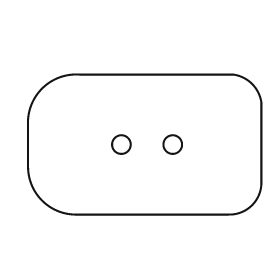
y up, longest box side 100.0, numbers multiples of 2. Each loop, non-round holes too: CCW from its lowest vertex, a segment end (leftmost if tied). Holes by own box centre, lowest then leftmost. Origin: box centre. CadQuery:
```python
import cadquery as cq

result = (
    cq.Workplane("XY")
    .moveTo(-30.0, -30.0)
    .lineTo(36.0, -30.0)
    .threePointArc((46.0, -26.0), (50.0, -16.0))
    .lineTo(50.0, 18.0)
    .threePointArc((46.0, 26.0), (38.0, 30.0))
    .lineTo(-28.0, 30.0)
    .threePointArc((-44.0, 24.0), (-50.0, 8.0))
    .lineTo(-50.0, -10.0)
    .threePointArc((-44.0, -24.0), (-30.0, -30.0))
    .close()
    .moveTo(-10.0, 0.0)
    .circle(4.0)
    .moveTo(12.0, 0.0)
    .circle(4.0)
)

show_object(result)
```